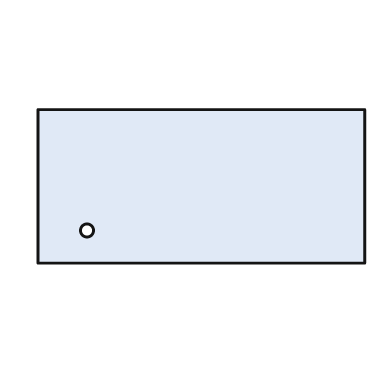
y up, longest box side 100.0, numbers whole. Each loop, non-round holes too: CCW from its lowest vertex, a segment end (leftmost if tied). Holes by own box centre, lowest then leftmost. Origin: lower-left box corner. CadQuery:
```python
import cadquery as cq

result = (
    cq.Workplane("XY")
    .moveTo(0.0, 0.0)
    .lineTo(100.0, 0.0)
    .lineTo(100.0, 47.0)
    .lineTo(0.0, 47.0)
    .close()
    .moveTo(15.0, 10.0)
    .circle(2.0)
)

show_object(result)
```